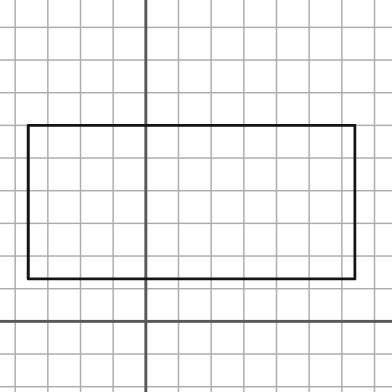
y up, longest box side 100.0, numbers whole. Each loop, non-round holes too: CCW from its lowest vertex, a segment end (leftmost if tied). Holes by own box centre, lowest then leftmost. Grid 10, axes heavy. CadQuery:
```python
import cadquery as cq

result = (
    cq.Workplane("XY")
    .moveTo(-36.0, 13.0)
    .lineTo(64.0, 13.0)
    .lineTo(64.0, 60.0)
    .lineTo(-36.0, 60.0)
    .close()
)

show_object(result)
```